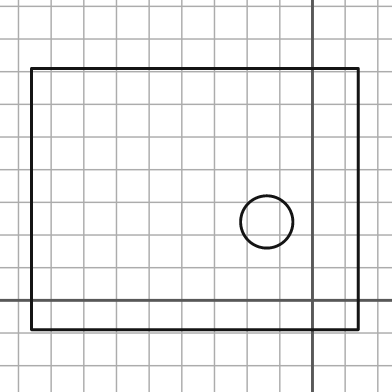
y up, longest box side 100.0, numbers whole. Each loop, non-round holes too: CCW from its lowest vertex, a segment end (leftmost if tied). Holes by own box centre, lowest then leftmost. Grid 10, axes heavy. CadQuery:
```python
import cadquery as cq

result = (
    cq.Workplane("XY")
    .moveTo(-86.0, -9.0)
    .lineTo(14.0, -9.0)
    .lineTo(14.0, 71.0)
    .lineTo(-86.0, 71.0)
    .close()
    .moveTo(-14.0, 24.0)
    .circle(8.0)
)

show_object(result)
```